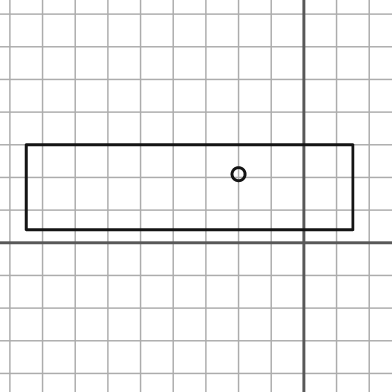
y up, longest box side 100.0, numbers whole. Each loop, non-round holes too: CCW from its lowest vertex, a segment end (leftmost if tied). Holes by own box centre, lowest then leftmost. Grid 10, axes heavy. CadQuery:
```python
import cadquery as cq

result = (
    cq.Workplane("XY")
    .moveTo(-85.0, 4.0)
    .lineTo(15.0, 4.0)
    .lineTo(15.0, 30.0)
    .lineTo(-85.0, 30.0)
    .close()
    .moveTo(-20.0, 21.0)
    .circle(2.0)
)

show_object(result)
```